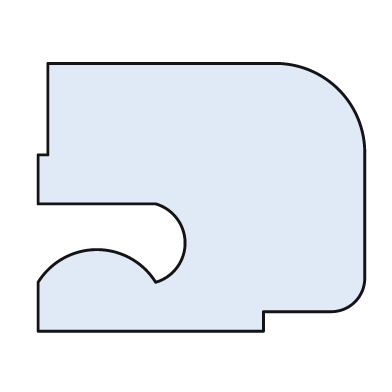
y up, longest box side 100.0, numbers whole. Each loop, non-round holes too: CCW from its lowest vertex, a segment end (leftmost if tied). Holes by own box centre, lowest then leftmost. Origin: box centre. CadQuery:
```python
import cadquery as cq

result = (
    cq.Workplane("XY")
    .moveTo(-50.0, -41.0)
    .lineTo(19.0, -41.0)
    .lineTo(19.0, -35.0)
    .lineTo(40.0, -35.0)
    .threePointArc((47.0, -32.0), (50.0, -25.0))
    .lineTo(50.0, 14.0)
    .threePointArc((42.0, 33.0), (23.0, 41.0))
    .lineTo(-47.0, 41.0)
    .lineTo(-47.0, 13.0)
    .lineTo(-50.0, 13.0)
    .lineTo(-50.0, -2.0)
    .lineTo(-14.0, -2.0)
    .threePointArc((-5.0, -14.0), (-14.0, -26.0))
    .threePointArc((-32.0, -16.0), (-50.0, -26.0))
    .close()
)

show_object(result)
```